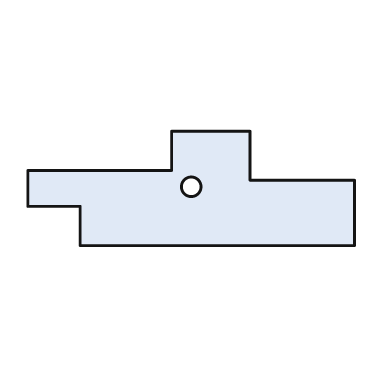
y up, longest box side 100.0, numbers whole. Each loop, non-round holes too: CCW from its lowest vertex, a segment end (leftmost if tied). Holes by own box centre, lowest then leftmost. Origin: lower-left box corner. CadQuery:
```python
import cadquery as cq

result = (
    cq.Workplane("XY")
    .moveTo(16.0, 0.0)
    .lineTo(100.0, 0.0)
    .lineTo(100.0, 20.0)
    .lineTo(68.0, 20.0)
    .lineTo(68.0, 35.0)
    .lineTo(44.0, 35.0)
    .lineTo(44.0, 23.0)
    .lineTo(0.0, 23.0)
    .lineTo(0.0, 12.0)
    .lineTo(16.0, 12.0)
    .close()
    .moveTo(50.0, 18.0)
    .circle(3.0)
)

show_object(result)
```